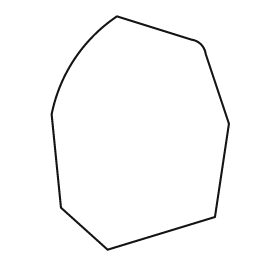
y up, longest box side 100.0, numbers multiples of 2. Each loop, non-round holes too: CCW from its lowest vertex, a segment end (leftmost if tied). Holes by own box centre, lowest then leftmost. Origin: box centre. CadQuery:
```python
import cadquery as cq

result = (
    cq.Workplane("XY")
    .moveTo(-14.0, -50.0)
    .lineTo(32.0, -36.0)
    .lineTo(38.0, 4.0)
    .lineTo(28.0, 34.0)
    .threePointArc((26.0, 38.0), (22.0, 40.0))
    .lineTo(-10.0, 50.0)
    .threePointArc((-28.0, 32.0), (-38.0, 8.0))
    .lineTo(-34.0, -32.0)
    .close()
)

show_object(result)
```